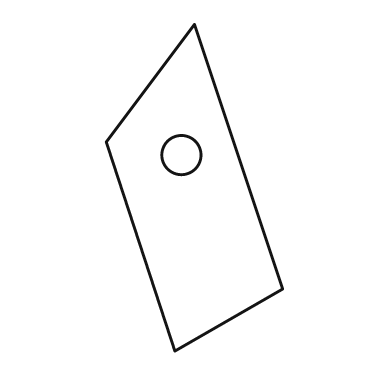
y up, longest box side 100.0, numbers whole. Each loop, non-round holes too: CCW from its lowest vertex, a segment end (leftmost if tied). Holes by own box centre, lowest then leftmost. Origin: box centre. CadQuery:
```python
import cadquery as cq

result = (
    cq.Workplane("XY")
    .moveTo(-6.0, -50.0)
    .lineTo(27.0, -31.0)
    .lineTo(0.0, 50.0)
    .lineTo(-27.0, 14.0)
    .close()
    .moveTo(-4.0, 10.0)
    .circle(6.0)
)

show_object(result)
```